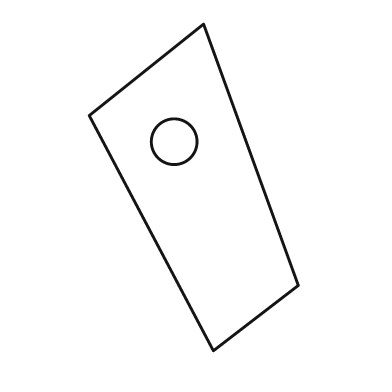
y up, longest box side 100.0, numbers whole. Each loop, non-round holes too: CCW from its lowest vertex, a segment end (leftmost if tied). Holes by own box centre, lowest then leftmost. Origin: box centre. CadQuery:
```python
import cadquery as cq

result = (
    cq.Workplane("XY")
    .moveTo(6.0, -50.0)
    .lineTo(32.0, -30.0)
    .lineTo(3.0, 50.0)
    .lineTo(-32.0, 22.0)
    .close()
    .moveTo(-6.0, 14.0)
    .circle(7.0)
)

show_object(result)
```